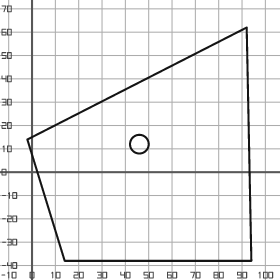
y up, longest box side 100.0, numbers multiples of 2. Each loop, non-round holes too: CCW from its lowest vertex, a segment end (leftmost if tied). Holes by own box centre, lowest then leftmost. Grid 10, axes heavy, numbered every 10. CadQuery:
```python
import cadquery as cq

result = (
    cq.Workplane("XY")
    .moveTo(14.0, -38.0)
    .lineTo(94.0, -38.0)
    .lineTo(92.0, 62.0)
    .lineTo(-2.0, 14.0)
    .close()
    .moveTo(46.0, 12.0)
    .circle(4.0)
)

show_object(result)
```